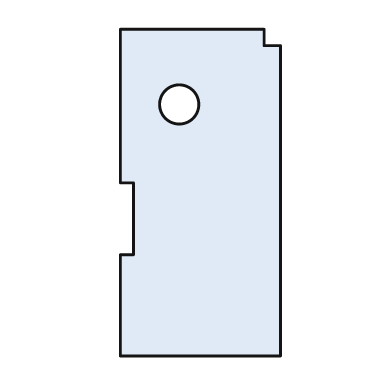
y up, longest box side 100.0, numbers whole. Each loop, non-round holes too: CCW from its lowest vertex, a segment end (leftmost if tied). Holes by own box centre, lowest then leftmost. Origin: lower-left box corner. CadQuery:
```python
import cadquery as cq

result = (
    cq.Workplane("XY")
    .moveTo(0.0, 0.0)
    .lineTo(49.0, 0.0)
    .lineTo(49.0, 95.0)
    .lineTo(44.0, 95.0)
    .lineTo(44.0, 100.0)
    .lineTo(0.0, 100.0)
    .lineTo(0.0, 53.0)
    .lineTo(4.0, 53.0)
    .lineTo(4.0, 31.0)
    .lineTo(0.0, 31.0)
    .close()
    .moveTo(18.0, 77.0)
    .circle(6.0)
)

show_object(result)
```